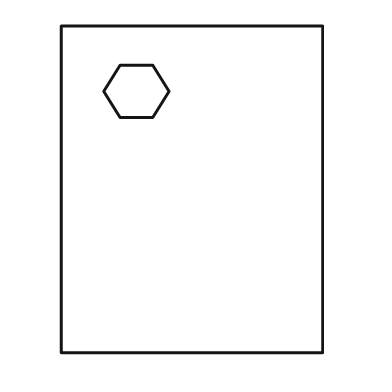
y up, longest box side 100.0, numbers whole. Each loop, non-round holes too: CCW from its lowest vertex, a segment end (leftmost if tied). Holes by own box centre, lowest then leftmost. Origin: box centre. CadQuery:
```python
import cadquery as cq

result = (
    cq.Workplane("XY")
    .moveTo(-40.0, -50.0)
    .lineTo(40.0, -50.0)
    .lineTo(40.0, 50.0)
    .lineTo(-40.0, 50.0)
    .close()
    .moveTo(-22.0, 22.0)
    .lineTo(-12.0, 22.0)
    .lineTo(-7.0, 30.0)
    .lineTo(-12.0, 38.0)
    .lineTo(-22.0, 38.0)
    .lineTo(-27.0, 30.0)
    .close()
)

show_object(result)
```